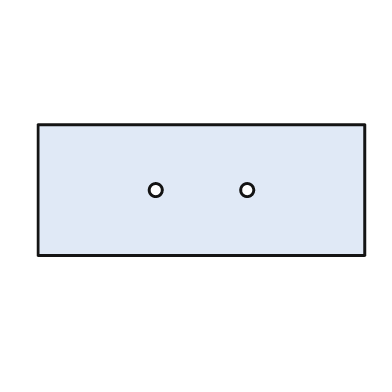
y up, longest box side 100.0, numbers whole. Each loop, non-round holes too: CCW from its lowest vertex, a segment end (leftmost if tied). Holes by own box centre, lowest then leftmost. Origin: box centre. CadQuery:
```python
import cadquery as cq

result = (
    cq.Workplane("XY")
    .moveTo(-50.0, -20.0)
    .lineTo(50.0, -20.0)
    .lineTo(50.0, 20.0)
    .lineTo(-50.0, 20.0)
    .close()
    .moveTo(-14.0, 0.0)
    .circle(2.0)
    .moveTo(14.0, 0.0)
    .circle(2.0)
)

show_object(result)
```